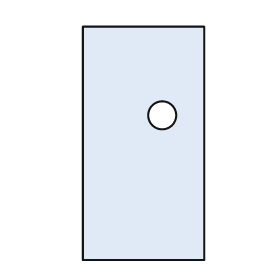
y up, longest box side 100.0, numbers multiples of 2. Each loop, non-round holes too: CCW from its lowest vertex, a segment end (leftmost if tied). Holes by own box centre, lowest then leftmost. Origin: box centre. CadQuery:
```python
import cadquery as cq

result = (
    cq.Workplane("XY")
    .moveTo(-26.0, -50.0)
    .lineTo(26.0, -50.0)
    .lineTo(26.0, 50.0)
    .lineTo(-26.0, 50.0)
    .close()
    .moveTo(8.0, 12.0)
    .circle(6.0)
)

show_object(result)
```